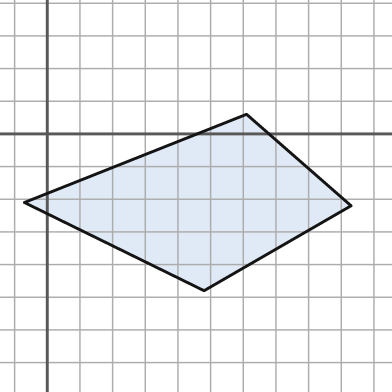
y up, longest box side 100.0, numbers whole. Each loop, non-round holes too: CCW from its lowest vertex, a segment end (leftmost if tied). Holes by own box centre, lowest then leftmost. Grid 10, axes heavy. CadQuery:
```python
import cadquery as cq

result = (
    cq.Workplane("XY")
    .moveTo(48.0, -48.0)
    .lineTo(93.0, -22.0)
    .lineTo(61.0, 6.0)
    .lineTo(-7.0, -21.0)
    .close()
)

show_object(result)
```